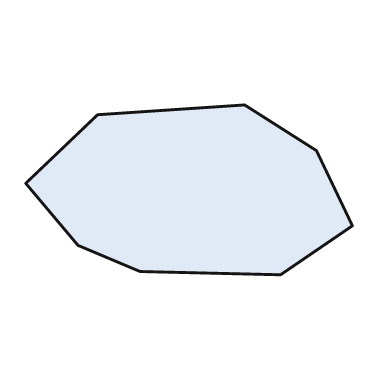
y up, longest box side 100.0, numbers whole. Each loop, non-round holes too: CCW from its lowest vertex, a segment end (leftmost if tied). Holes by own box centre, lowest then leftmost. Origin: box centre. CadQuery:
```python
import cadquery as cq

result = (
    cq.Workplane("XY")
    .moveTo(28.0, -26.0)
    .lineTo(50.0, -11.0)
    .lineTo(39.0, 12.0)
    .lineTo(17.0, 26.0)
    .lineTo(-28.0, 23.0)
    .lineTo(-50.0, 2.0)
    .lineTo(-34.0, -17.0)
    .lineTo(-15.0, -25.0)
    .close()
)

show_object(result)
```